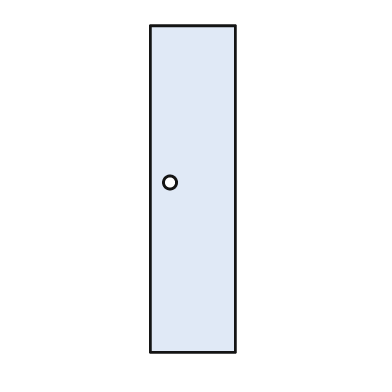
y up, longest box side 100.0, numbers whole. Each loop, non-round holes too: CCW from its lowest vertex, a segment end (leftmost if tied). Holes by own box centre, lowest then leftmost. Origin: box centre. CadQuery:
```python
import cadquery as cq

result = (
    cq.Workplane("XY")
    .moveTo(-13.0, -50.0)
    .lineTo(13.0, -50.0)
    .lineTo(13.0, 50.0)
    .lineTo(-13.0, 50.0)
    .close()
    .moveTo(-7.0, 2.0)
    .circle(2.0)
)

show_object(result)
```